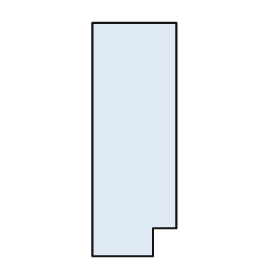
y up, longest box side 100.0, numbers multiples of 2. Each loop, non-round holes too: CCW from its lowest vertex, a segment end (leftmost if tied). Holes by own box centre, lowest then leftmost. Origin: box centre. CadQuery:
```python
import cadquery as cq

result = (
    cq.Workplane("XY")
    .moveTo(-18.0, -50.0)
    .lineTo(8.0, -50.0)
    .lineTo(8.0, -38.0)
    .lineTo(18.0, -38.0)
    .lineTo(18.0, 50.0)
    .lineTo(-18.0, 50.0)
    .close()
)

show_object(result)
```